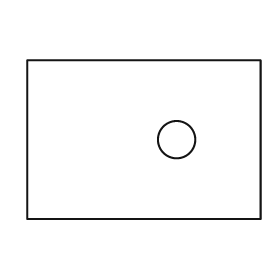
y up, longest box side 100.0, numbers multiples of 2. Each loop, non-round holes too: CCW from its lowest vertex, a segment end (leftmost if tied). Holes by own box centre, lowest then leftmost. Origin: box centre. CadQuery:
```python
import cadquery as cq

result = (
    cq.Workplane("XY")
    .moveTo(-50.0, -34.0)
    .lineTo(50.0, -34.0)
    .lineTo(50.0, 34.0)
    .lineTo(-50.0, 34.0)
    .close()
    .moveTo(14.0, 0.0)
    .circle(8.0)
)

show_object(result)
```